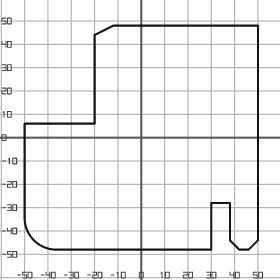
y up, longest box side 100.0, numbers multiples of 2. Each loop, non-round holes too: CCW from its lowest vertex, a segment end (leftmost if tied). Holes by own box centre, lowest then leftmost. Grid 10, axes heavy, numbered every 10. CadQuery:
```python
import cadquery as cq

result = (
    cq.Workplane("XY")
    .moveTo(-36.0, -48.0)
    .lineTo(30.0, -48.0)
    .lineTo(30.0, -28.0)
    .lineTo(38.0, -28.0)
    .lineTo(38.0, -44.0)
    .lineTo(42.0, -48.0)
    .lineTo(46.0, -48.0)
    .lineTo(50.0, -44.0)
    .lineTo(50.0, 48.0)
    .lineTo(-12.0, 48.0)
    .lineTo(-20.0, 44.0)
    .lineTo(-20.0, 6.0)
    .lineTo(-50.0, 6.0)
    .lineTo(-50.0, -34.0)
    .threePointArc((-46.0, -44.0), (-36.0, -48.0))
    .close()
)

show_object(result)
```